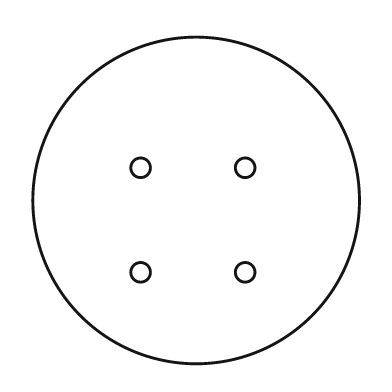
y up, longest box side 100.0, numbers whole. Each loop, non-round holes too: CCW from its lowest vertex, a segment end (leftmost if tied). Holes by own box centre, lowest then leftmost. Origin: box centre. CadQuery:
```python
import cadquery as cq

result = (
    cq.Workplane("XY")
    .moveTo(0.0, 0.0)
    .circle(50.0)
    .moveTo(-17.0, -22.0)
    .circle(3.0)
    .moveTo(15.0, -22.0)
    .circle(3.0)
    .moveTo(-17.0, 10.0)
    .circle(3.0)
    .moveTo(15.0, 10.0)
    .circle(3.0)
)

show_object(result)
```